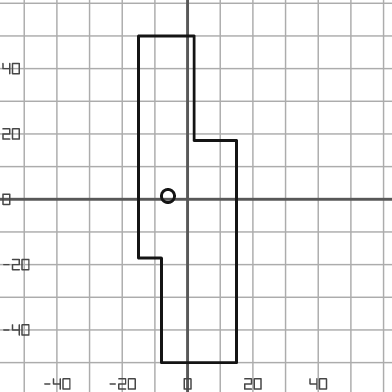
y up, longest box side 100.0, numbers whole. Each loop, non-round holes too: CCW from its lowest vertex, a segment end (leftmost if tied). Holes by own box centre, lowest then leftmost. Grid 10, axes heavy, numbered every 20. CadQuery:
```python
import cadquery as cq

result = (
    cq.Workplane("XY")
    .moveTo(-8.0, -50.0)
    .lineTo(15.0, -50.0)
    .lineTo(15.0, 18.0)
    .lineTo(2.0, 18.0)
    .lineTo(2.0, 50.0)
    .lineTo(-15.0, 50.0)
    .lineTo(-15.0, -18.0)
    .lineTo(-8.0, -18.0)
    .close()
    .moveTo(-6.0, 1.0)
    .circle(2.0)
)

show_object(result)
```